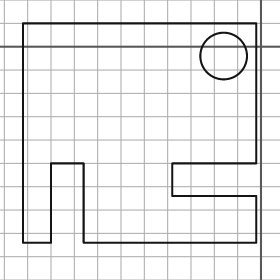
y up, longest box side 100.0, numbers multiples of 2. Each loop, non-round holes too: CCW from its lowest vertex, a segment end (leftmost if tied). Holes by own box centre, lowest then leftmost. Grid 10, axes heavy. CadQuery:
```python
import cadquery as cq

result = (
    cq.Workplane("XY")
    .moveTo(-102.0, -84.0)
    .lineTo(-90.0, -84.0)
    .lineTo(-90.0, -50.0)
    .lineTo(-76.0, -50.0)
    .lineTo(-76.0, -84.0)
    .lineTo(-2.0, -84.0)
    .lineTo(-2.0, -64.0)
    .lineTo(-38.0, -64.0)
    .lineTo(-38.0, -50.0)
    .lineTo(-2.0, -50.0)
    .lineTo(-2.0, 10.0)
    .lineTo(-102.0, 10.0)
    .close()
    .moveTo(-16.0, -4.0)
    .circle(10.0)
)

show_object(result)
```